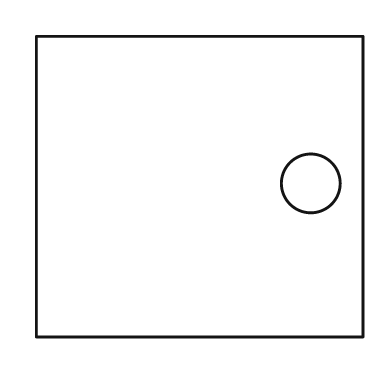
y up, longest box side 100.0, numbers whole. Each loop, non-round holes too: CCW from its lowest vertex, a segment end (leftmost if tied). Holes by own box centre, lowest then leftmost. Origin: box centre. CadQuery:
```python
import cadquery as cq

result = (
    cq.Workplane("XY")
    .moveTo(-50.0, -46.0)
    .lineTo(50.0, -46.0)
    .lineTo(50.0, 46.0)
    .lineTo(-50.0, 46.0)
    .close()
    .moveTo(34.0, 1.0)
    .circle(9.0)
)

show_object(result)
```